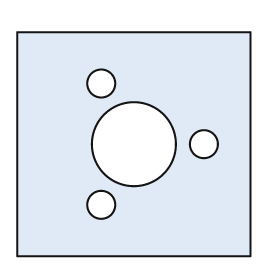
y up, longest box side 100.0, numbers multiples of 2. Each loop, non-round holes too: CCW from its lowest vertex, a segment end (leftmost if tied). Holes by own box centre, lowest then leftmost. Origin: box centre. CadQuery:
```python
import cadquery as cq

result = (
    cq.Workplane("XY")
    .moveTo(-50.0, -48.0)
    .lineTo(50.0, -48.0)
    .lineTo(50.0, 48.0)
    .lineTo(-50.0, 48.0)
    .close()
    .moveTo(-14.0, -26.0)
    .circle(6.0)
    .moveTo(0.0, 0.0)
    .circle(18.0)
    .moveTo(30.0, 0.0)
    .circle(6.0)
    .moveTo(-14.0, 26.0)
    .circle(6.0)
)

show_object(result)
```